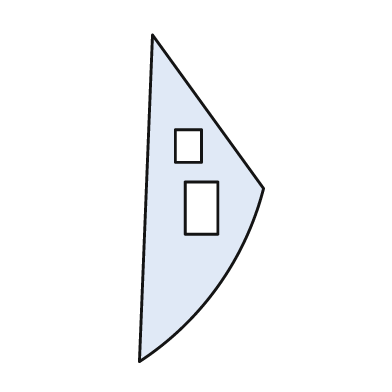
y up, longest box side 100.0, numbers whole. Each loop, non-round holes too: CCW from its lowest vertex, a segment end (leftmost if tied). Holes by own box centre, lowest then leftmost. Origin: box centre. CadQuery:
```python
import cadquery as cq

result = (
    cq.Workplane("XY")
    .moveTo(-19.0, -50.0)
    .threePointArc((5.0, -27.0), (19.0, 3.0))
    .lineTo(-15.0, 50.0)
    .close()
    .moveTo(-5.0, -11.0)
    .lineTo(5.0, -11.0)
    .lineTo(5.0, 5.0)
    .lineTo(-5.0, 5.0)
    .close()
    .moveTo(-8.0, 11.0)
    .lineTo(0.0, 11.0)
    .lineTo(0.0, 21.0)
    .lineTo(-8.0, 21.0)
    .close()
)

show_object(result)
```